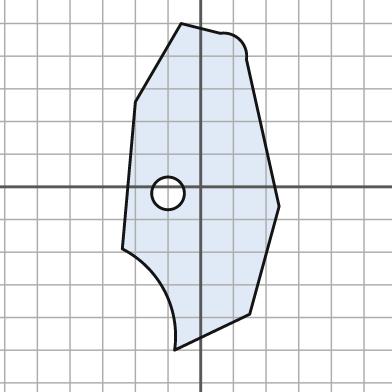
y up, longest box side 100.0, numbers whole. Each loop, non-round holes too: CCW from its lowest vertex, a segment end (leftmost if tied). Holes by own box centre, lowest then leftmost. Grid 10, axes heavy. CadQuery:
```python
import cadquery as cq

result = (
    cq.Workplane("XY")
    .moveTo(-8.0, -50.0)
    .lineTo(15.0, -39.0)
    .lineTo(24.0, -6.0)
    .lineTo(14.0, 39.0)
    .threePointArc((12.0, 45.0), (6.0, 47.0))
    .lineTo(-6.0, 50.0)
    .lineTo(-20.0, 26.0)
    .lineTo(-24.0, -19.0)
    .threePointArc((-11.0, -32.0), (-8.0, -50.0))
    .close()
    .moveTo(-10.0, -2.0)
    .circle(5.0)
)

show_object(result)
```